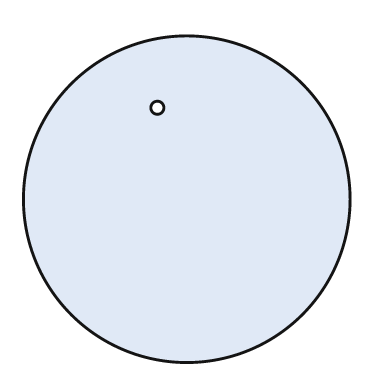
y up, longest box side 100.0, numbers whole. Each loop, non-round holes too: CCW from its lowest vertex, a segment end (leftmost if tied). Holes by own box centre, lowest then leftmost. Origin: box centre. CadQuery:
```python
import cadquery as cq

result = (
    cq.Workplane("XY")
    .moveTo(0.0, 0.0)
    .circle(50.0)
    .moveTo(-9.0, 28.0)
    .circle(2.0)
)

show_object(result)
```